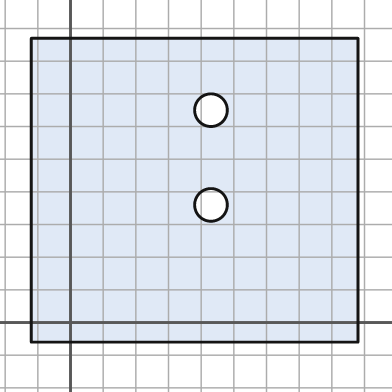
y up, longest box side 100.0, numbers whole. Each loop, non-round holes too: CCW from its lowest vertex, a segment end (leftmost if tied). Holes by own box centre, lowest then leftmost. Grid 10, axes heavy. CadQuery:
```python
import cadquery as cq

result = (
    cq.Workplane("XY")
    .moveTo(-12.0, -6.0)
    .lineTo(88.0, -6.0)
    .lineTo(88.0, 87.0)
    .lineTo(-12.0, 87.0)
    .close()
    .moveTo(43.0, 36.0)
    .circle(5.0)
    .moveTo(43.0, 65.0)
    .circle(5.0)
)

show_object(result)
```